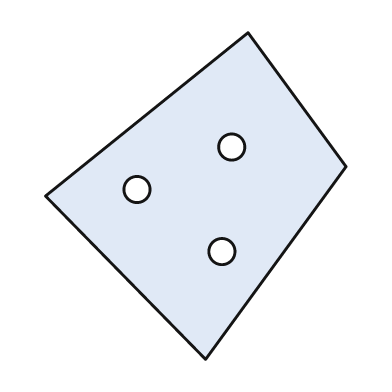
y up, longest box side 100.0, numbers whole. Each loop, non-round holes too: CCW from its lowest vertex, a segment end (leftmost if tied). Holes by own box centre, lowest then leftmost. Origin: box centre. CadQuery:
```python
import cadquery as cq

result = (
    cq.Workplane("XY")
    .moveTo(3.0, -50.0)
    .lineTo(46.0, 9.0)
    .lineTo(16.0, 50.0)
    .lineTo(-46.0, 0.0)
    .close()
    .moveTo(8.0, -17.0)
    .circle(4.0)
    .moveTo(-18.0, 2.0)
    .circle(4.0)
    .moveTo(11.0, 15.0)
    .circle(4.0)
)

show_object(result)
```